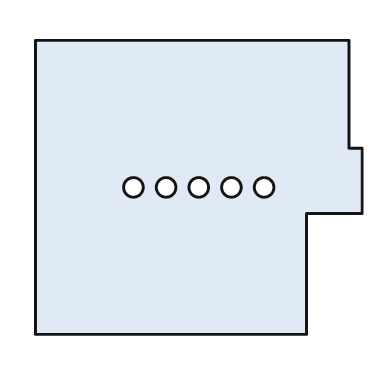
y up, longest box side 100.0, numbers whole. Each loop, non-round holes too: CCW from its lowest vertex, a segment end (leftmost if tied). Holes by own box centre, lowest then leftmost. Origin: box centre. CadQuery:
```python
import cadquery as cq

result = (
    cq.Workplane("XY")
    .moveTo(-50.0, -45.0)
    .lineTo(33.0, -45.0)
    .lineTo(33.0, -8.0)
    .lineTo(50.0, -8.0)
    .lineTo(50.0, 12.0)
    .lineTo(46.0, 12.0)
    .lineTo(46.0, 45.0)
    .lineTo(-50.0, 45.0)
    .close()
    .moveTo(-20.0, 0.0)
    .circle(3.0)
    .moveTo(-10.0, 0.0)
    .circle(3.0)
    .moveTo(0.0, 0.0)
    .circle(3.0)
    .moveTo(10.0, 0.0)
    .circle(3.0)
    .moveTo(20.0, 0.0)
    .circle(3.0)
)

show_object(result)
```